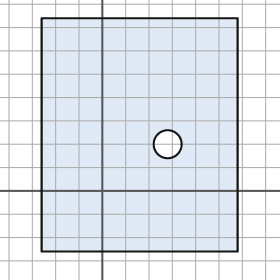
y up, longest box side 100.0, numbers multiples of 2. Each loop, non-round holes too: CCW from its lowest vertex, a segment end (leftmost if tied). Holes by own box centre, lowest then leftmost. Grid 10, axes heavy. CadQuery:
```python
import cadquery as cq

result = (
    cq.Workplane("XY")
    .moveTo(-26.0, -26.0)
    .lineTo(58.0, -26.0)
    .lineTo(58.0, 74.0)
    .lineTo(-26.0, 74.0)
    .close()
    .moveTo(28.0, 20.0)
    .circle(6.0)
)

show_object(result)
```